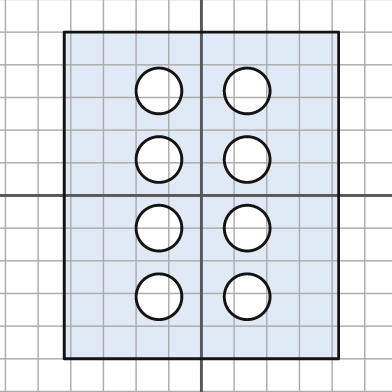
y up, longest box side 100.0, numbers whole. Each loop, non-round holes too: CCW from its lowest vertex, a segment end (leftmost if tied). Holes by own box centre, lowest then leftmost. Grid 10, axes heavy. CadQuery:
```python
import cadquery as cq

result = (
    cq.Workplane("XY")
    .moveTo(-42.0, -50.0)
    .lineTo(42.0, -50.0)
    .lineTo(42.0, 50.0)
    .lineTo(-42.0, 50.0)
    .close()
    .moveTo(-13.0, -31.0)
    .circle(7.0)
    .moveTo(14.0, -31.0)
    .circle(7.0)
    .moveTo(-13.0, -10.0)
    .circle(7.0)
    .moveTo(14.0, -10.0)
    .circle(7.0)
    .moveTo(-13.0, 11.0)
    .circle(7.0)
    .moveTo(14.0, 11.0)
    .circle(7.0)
    .moveTo(-13.0, 32.0)
    .circle(7.0)
    .moveTo(14.0, 32.0)
    .circle(7.0)
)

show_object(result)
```